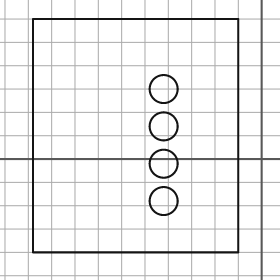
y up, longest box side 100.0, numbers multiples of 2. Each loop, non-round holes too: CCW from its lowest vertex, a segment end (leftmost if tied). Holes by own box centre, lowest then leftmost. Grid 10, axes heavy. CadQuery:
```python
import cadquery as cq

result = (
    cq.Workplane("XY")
    .moveTo(-98.0, -40.0)
    .lineTo(-10.0, -40.0)
    .lineTo(-10.0, 60.0)
    .lineTo(-98.0, 60.0)
    .close()
    .moveTo(-42.0, -18.0)
    .circle(6.0)
    .moveTo(-42.0, -2.0)
    .circle(6.0)
    .moveTo(-42.0, 14.0)
    .circle(6.0)
    .moveTo(-42.0, 30.0)
    .circle(6.0)
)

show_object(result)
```